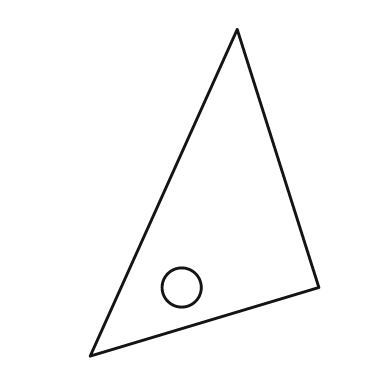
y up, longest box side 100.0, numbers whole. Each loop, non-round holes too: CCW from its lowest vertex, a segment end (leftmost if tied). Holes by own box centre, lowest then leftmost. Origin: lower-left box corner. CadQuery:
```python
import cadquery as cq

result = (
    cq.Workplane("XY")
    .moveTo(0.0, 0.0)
    .lineTo(70.0, 21.0)
    .lineTo(45.0, 100.0)
    .close()
    .moveTo(28.0, 21.0)
    .circle(6.0)
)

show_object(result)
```